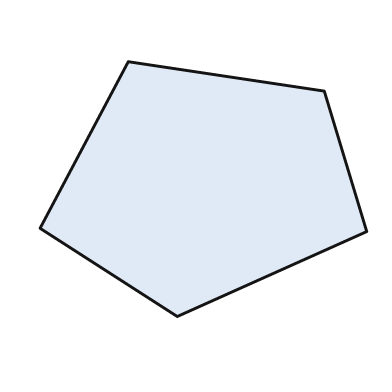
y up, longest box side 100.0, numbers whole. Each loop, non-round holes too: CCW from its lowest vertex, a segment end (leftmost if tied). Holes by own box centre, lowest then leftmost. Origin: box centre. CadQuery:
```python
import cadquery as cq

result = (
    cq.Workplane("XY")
    .moveTo(-8.0, -39.0)
    .lineTo(50.0, -13.0)
    .lineTo(37.0, 30.0)
    .lineTo(-23.0, 39.0)
    .lineTo(-50.0, -12.0)
    .close()
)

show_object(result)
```